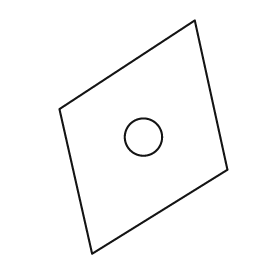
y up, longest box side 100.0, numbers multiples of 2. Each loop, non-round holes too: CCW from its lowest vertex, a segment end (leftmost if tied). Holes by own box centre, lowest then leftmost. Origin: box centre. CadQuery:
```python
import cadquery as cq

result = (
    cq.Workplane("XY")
    .moveTo(-22.0, -50.0)
    .lineTo(36.0, -14.0)
    .lineTo(22.0, 50.0)
    .lineTo(-36.0, 12.0)
    .close()
    .moveTo(0.0, 0.0)
    .circle(8.0)
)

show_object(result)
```